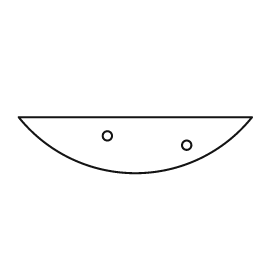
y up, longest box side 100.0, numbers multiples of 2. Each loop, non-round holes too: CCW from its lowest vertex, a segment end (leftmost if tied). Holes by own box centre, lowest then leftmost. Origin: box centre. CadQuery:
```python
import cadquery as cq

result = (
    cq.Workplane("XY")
    .moveTo(-50.0, 12.0)
    .threePointArc((0.0, -12.0), (50.0, 12.0))
    .close()
    .moveTo(22.0, 0.0)
    .circle(2.0)
    .moveTo(-12.0, 4.0)
    .circle(2.0)
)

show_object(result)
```